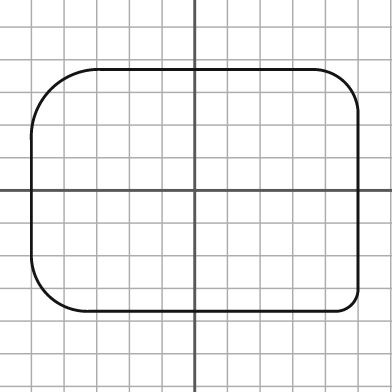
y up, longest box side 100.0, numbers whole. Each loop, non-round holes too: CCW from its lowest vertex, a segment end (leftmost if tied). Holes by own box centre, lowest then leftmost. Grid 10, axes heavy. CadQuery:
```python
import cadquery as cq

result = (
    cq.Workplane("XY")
    .moveTo(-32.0, -37.0)
    .lineTo(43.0, -37.0)
    .threePointArc((48.0, -35.0), (50.0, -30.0))
    .lineTo(50.0, 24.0)
    .threePointArc((46.0, 33.0), (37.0, 37.0))
    .lineTo(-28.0, 37.0)
    .threePointArc((-44.0, 31.0), (-50.0, 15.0))
    .lineTo(-50.0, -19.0)
    .threePointArc((-45.0, -32.0), (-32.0, -37.0))
    .close()
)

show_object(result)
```